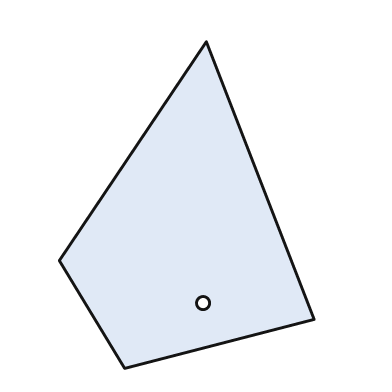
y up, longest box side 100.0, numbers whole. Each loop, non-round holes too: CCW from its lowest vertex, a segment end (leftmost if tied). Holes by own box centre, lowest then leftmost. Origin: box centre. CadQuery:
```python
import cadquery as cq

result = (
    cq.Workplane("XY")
    .moveTo(-19.0, -50.0)
    .lineTo(39.0, -35.0)
    .lineTo(6.0, 50.0)
    .lineTo(-39.0, -17.0)
    .close()
    .moveTo(5.0, -30.0)
    .circle(2.0)
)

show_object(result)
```